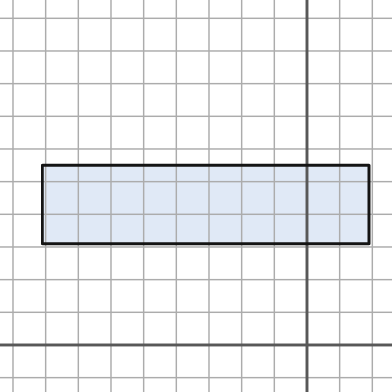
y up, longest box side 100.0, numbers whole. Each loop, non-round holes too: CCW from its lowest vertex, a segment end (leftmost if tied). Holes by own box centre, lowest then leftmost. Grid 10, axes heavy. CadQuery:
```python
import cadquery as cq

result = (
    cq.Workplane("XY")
    .moveTo(-81.0, 31.0)
    .lineTo(19.0, 31.0)
    .lineTo(19.0, 55.0)
    .lineTo(-81.0, 55.0)
    .close()
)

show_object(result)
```